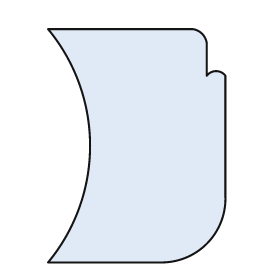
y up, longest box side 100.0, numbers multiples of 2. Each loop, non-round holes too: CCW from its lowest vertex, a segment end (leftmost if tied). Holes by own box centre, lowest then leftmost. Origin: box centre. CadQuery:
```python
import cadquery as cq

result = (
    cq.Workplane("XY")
    .moveTo(-38.0, -50.0)
    .lineTo(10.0, -50.0)
    .threePointArc((30.0, -42.0), (38.0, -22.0))
    .lineTo(38.0, 30.0)
    .threePointArc((34.0, 32.0), (30.0, 30.0))
    .lineTo(30.0, 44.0)
    .threePointArc((28.0, 48.0), (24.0, 50.0))
    .lineTo(-38.0, 50.0)
    .threePointArc((-20.0, 0.0), (-38.0, -50.0))
    .close()
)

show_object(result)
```